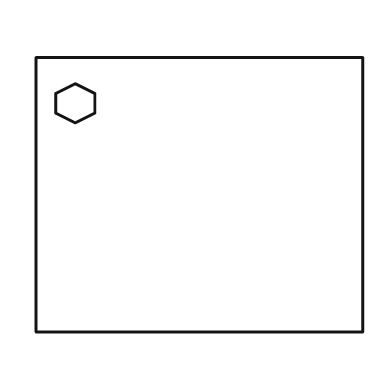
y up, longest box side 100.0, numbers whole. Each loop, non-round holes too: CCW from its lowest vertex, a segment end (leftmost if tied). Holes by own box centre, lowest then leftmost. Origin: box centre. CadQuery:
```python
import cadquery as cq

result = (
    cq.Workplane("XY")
    .moveTo(-50.0, -42.0)
    .lineTo(50.0, -42.0)
    .lineTo(50.0, 42.0)
    .lineTo(-50.0, 42.0)
    .close()
    .moveTo(-38.0, 22.0)
    .lineTo(-32.0, 25.0)
    .lineTo(-32.0, 31.0)
    .lineTo(-38.0, 34.0)
    .lineTo(-44.0, 31.0)
    .lineTo(-44.0, 25.0)
    .close()
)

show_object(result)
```